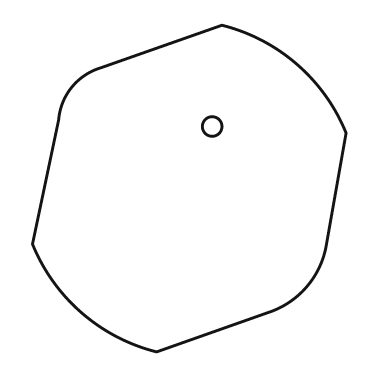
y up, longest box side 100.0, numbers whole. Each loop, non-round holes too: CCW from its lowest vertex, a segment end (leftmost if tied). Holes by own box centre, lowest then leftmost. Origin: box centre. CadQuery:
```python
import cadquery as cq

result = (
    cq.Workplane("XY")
    .moveTo(-10.0, -50.0)
    .lineTo(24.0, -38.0)
    .threePointArc((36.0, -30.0), (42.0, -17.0))
    .lineTo(48.0, 17.0)
    .threePointArc((33.0, 38.0), (10.0, 50.0))
    .lineTo(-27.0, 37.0)
    .threePointArc((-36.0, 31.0), (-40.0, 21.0))
    .lineTo(-48.0, -17.0)
    .threePointArc((-33.0, -38.0), (-10.0, -50.0))
    .close()
    .moveTo(7.0, 19.0)
    .circle(3.0)
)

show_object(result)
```